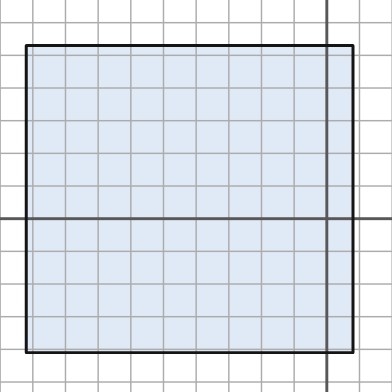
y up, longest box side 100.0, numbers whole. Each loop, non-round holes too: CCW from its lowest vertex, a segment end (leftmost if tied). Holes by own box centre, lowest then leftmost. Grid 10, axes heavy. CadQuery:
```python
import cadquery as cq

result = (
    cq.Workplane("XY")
    .moveTo(-92.0, -41.0)
    .lineTo(8.0, -41.0)
    .lineTo(8.0, 53.0)
    .lineTo(-92.0, 53.0)
    .close()
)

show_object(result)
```